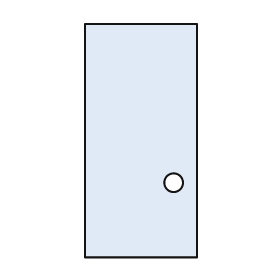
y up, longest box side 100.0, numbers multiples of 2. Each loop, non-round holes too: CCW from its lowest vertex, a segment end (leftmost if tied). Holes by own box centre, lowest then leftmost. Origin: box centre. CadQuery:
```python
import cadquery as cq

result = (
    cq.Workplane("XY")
    .moveTo(-24.0, -50.0)
    .lineTo(24.0, -50.0)
    .lineTo(24.0, 50.0)
    .lineTo(-24.0, 50.0)
    .close()
    .moveTo(14.0, -18.0)
    .circle(4.0)
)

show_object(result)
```